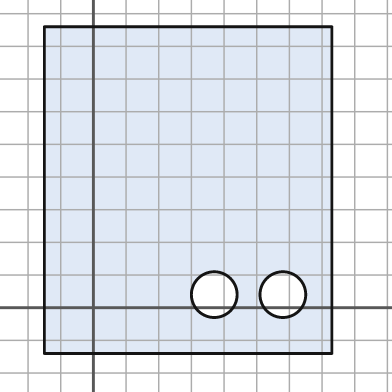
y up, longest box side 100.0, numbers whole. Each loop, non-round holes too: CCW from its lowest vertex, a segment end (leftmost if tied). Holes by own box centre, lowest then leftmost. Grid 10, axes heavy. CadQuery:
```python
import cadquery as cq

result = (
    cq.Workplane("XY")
    .moveTo(-15.0, -14.0)
    .lineTo(73.0, -14.0)
    .lineTo(73.0, 86.0)
    .lineTo(-15.0, 86.0)
    .close()
    .moveTo(37.0, 4.0)
    .circle(7.0)
    .moveTo(58.0, 4.0)
    .circle(7.0)
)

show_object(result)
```